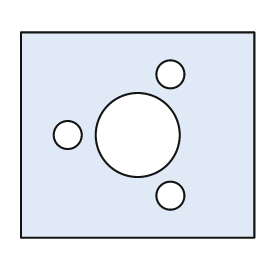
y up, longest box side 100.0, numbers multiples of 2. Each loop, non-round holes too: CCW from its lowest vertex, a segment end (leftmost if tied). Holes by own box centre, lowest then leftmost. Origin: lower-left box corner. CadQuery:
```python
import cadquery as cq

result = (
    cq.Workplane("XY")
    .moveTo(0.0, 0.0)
    .lineTo(100.0, 0.0)
    .lineTo(100.0, 88.0)
    .lineTo(0.0, 88.0)
    .close()
    .moveTo(64.0, 18.0)
    .circle(6.0)
    .moveTo(20.0, 44.0)
    .circle(6.0)
    .moveTo(50.0, 44.0)
    .circle(18.0)
    .moveTo(64.0, 70.0)
    .circle(6.0)
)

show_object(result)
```